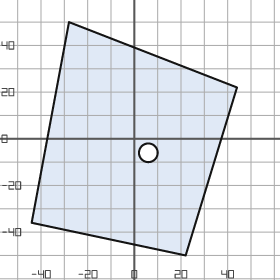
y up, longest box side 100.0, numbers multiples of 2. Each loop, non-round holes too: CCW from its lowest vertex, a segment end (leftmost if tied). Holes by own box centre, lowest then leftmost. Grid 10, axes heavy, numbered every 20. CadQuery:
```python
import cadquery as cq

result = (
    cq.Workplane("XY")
    .moveTo(22.0, -50.0)
    .lineTo(44.0, 22.0)
    .lineTo(-28.0, 50.0)
    .lineTo(-44.0, -36.0)
    .close()
    .moveTo(6.0, -6.0)
    .circle(4.0)
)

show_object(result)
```